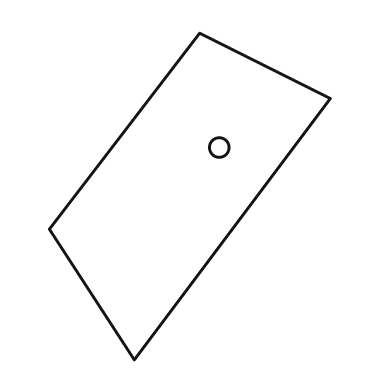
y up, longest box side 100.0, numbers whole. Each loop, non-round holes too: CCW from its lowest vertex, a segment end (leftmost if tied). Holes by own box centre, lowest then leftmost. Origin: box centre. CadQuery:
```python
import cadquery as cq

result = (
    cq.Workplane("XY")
    .moveTo(-17.0, -50.0)
    .lineTo(43.0, 30.0)
    .lineTo(3.0, 50.0)
    .lineTo(-43.0, -10.0)
    .close()
    .moveTo(9.0, 15.0)
    .circle(3.0)
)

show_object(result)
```